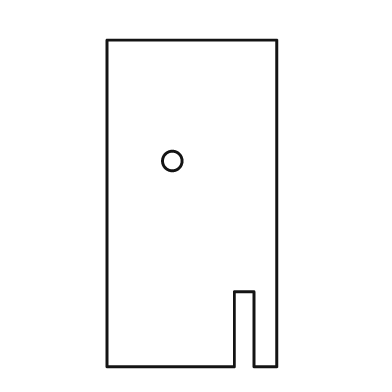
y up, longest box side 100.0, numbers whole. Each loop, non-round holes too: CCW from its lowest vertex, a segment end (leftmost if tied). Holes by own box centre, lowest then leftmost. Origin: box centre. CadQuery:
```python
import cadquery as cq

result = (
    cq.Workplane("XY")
    .moveTo(-26.0, -50.0)
    .lineTo(13.0, -50.0)
    .lineTo(13.0, -27.0)
    .lineTo(19.0, -27.0)
    .lineTo(19.0, -50.0)
    .lineTo(26.0, -50.0)
    .lineTo(26.0, 50.0)
    .lineTo(-26.0, 50.0)
    .close()
    .moveTo(-6.0, 13.0)
    .circle(3.0)
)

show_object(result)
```